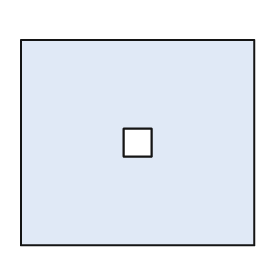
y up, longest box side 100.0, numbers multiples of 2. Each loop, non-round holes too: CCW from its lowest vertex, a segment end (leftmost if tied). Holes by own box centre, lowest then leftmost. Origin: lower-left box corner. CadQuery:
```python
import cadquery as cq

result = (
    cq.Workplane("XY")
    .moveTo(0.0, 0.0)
    .lineTo(100.0, 0.0)
    .lineTo(100.0, 88.0)
    .lineTo(0.0, 88.0)
    .close()
    .moveTo(44.0, 38.0)
    .lineTo(56.0, 38.0)
    .lineTo(56.0, 50.0)
    .lineTo(44.0, 50.0)
    .close()
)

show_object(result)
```